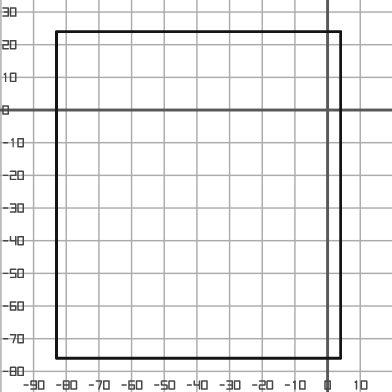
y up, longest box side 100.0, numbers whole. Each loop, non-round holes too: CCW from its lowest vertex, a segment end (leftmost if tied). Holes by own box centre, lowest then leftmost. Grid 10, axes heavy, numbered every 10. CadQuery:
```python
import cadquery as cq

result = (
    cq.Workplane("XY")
    .moveTo(-83.0, -76.0)
    .lineTo(4.0, -76.0)
    .lineTo(4.0, 24.0)
    .lineTo(-83.0, 24.0)
    .close()
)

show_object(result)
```